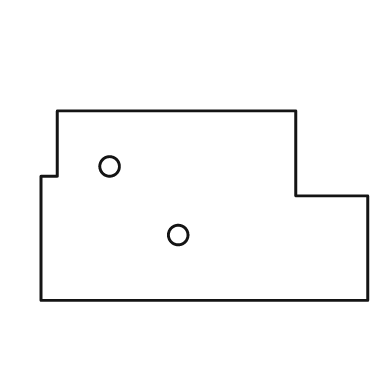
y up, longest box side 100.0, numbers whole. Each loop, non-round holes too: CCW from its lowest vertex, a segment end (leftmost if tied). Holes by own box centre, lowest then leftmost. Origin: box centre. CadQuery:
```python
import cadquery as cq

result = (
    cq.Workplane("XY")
    .moveTo(-50.0, -29.0)
    .lineTo(50.0, -29.0)
    .lineTo(50.0, 3.0)
    .lineTo(28.0, 3.0)
    .lineTo(28.0, 29.0)
    .lineTo(-45.0, 29.0)
    .lineTo(-45.0, 9.0)
    .lineTo(-50.0, 9.0)
    .close()
    .moveTo(-8.0, -9.0)
    .circle(3.0)
    .moveTo(-29.0, 12.0)
    .circle(3.0)
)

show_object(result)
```